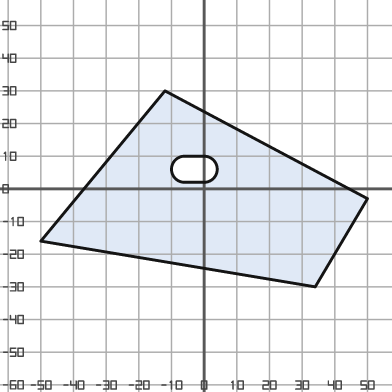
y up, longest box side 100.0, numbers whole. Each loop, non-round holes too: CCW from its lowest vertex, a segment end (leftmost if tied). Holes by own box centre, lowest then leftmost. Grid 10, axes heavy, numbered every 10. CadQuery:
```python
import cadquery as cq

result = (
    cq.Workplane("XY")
    .moveTo(34.0, -30.0)
    .lineTo(50.0, -3.0)
    .lineTo(-12.0, 30.0)
    .lineTo(-50.0, -16.0)
    .close()
    .moveTo(-6.0, 2.0)
    .lineTo(0.0, 2.0)
    .threePointArc((4.0, 6.0), (0.0, 10.0))
    .lineTo(-6.0, 10.0)
    .threePointArc((-10.0, 6.0), (-6.0, 2.0))
    .close()
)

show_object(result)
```